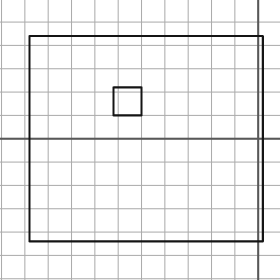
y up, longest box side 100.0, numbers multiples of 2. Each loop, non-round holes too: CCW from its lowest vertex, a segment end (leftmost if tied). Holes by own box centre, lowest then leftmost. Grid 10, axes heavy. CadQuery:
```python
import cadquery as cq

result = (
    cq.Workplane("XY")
    .moveTo(-98.0, -44.0)
    .lineTo(2.0, -44.0)
    .lineTo(2.0, 44.0)
    .lineTo(-98.0, 44.0)
    .close()
    .moveTo(-62.0, 10.0)
    .lineTo(-50.0, 10.0)
    .lineTo(-50.0, 22.0)
    .lineTo(-62.0, 22.0)
    .close()
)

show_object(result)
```